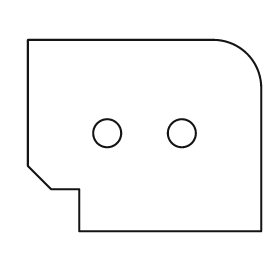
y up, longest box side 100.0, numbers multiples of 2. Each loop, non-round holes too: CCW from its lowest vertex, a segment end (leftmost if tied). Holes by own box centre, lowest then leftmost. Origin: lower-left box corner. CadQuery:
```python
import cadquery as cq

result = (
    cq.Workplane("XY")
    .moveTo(22.0, 0.0)
    .lineTo(100.0, 0.0)
    .lineTo(100.0, 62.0)
    .threePointArc((94.0, 76.0), (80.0, 82.0))
    .lineTo(0.0, 82.0)
    .lineTo(0.0, 28.0)
    .lineTo(10.0, 18.0)
    .lineTo(22.0, 18.0)
    .close()
    .moveTo(34.0, 42.0)
    .circle(6.0)
    .moveTo(66.0, 42.0)
    .circle(6.0)
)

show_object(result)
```